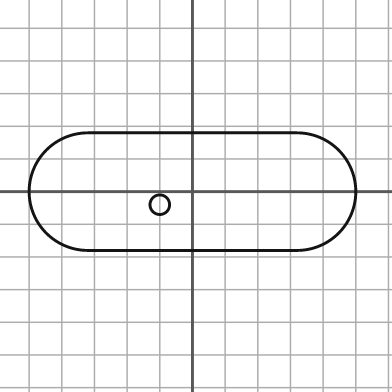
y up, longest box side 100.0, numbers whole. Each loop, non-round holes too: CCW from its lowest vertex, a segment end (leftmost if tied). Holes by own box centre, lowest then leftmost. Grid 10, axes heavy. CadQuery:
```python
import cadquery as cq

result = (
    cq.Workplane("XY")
    .moveTo(-32.0, -18.0)
    .lineTo(32.0, -18.0)
    .threePointArc((50.0, 0.0), (32.0, 18.0))
    .lineTo(-32.0, 18.0)
    .threePointArc((-50.0, 0.0), (-32.0, -18.0))
    .close()
    .moveTo(-10.0, -4.0)
    .circle(3.0)
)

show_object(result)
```